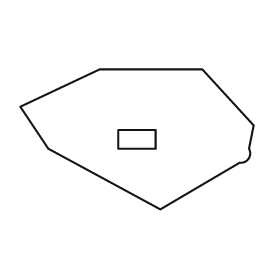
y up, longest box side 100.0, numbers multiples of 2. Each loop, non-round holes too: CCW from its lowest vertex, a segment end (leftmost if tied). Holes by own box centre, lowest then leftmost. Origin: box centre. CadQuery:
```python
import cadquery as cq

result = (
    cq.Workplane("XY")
    .moveTo(10.0, -30.0)
    .lineTo(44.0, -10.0)
    .threePointArc((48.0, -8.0), (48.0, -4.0))
    .lineTo(50.0, 6.0)
    .lineTo(28.0, 30.0)
    .lineTo(-16.0, 30.0)
    .lineTo(-50.0, 14.0)
    .lineTo(-38.0, -4.0)
    .close()
    .moveTo(-8.0, -4.0)
    .lineTo(8.0, -4.0)
    .lineTo(8.0, 4.0)
    .lineTo(-8.0, 4.0)
    .close()
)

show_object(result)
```